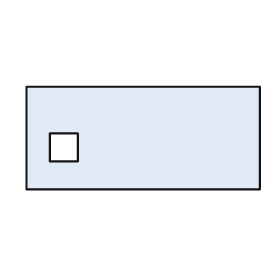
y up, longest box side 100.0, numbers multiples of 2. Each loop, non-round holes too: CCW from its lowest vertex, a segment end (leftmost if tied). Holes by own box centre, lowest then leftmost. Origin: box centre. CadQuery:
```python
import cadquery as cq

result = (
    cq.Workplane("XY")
    .moveTo(-50.0, -22.0)
    .lineTo(50.0, -22.0)
    .lineTo(50.0, 22.0)
    .lineTo(-50.0, 22.0)
    .close()
    .moveTo(-40.0, -10.0)
    .lineTo(-28.0, -10.0)
    .lineTo(-28.0, 2.0)
    .lineTo(-40.0, 2.0)
    .close()
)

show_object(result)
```